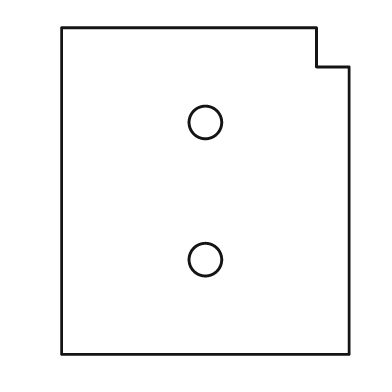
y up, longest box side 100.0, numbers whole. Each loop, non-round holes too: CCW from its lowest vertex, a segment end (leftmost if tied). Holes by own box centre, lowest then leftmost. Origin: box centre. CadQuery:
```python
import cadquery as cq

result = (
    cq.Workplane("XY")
    .moveTo(-44.0, -50.0)
    .lineTo(44.0, -50.0)
    .lineTo(44.0, 38.0)
    .lineTo(34.0, 38.0)
    .lineTo(34.0, 50.0)
    .lineTo(-44.0, 50.0)
    .close()
    .moveTo(0.0, -21.0)
    .circle(5.0)
    .moveTo(0.0, 21.0)
    .circle(5.0)
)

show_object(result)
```